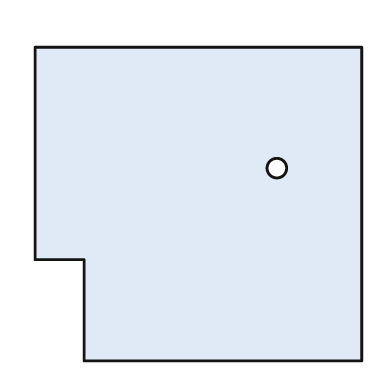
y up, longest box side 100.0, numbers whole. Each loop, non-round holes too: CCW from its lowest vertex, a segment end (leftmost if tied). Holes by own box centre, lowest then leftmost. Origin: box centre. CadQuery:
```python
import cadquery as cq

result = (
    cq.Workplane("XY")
    .moveTo(-35.0, -48.0)
    .lineTo(50.0, -48.0)
    .lineTo(50.0, 48.0)
    .lineTo(-50.0, 48.0)
    .lineTo(-50.0, -17.0)
    .lineTo(-35.0, -17.0)
    .close()
    .moveTo(24.0, 11.0)
    .circle(3.0)
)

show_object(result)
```